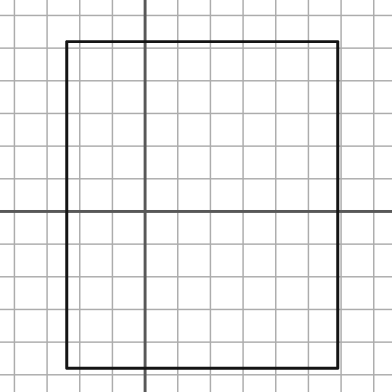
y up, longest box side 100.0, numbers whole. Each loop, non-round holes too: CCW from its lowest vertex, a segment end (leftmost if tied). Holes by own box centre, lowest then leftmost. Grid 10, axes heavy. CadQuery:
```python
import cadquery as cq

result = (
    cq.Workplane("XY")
    .moveTo(-24.0, -48.0)
    .lineTo(59.0, -48.0)
    .lineTo(59.0, 52.0)
    .lineTo(-24.0, 52.0)
    .close()
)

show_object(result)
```